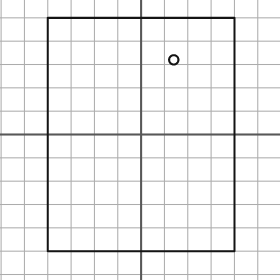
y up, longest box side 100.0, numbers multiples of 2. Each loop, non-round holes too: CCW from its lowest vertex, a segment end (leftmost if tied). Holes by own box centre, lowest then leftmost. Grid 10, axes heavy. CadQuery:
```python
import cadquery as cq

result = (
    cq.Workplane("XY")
    .moveTo(-40.0, -50.0)
    .lineTo(40.0, -50.0)
    .lineTo(40.0, 50.0)
    .lineTo(-40.0, 50.0)
    .close()
    .moveTo(14.0, 32.0)
    .circle(2.0)
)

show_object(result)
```